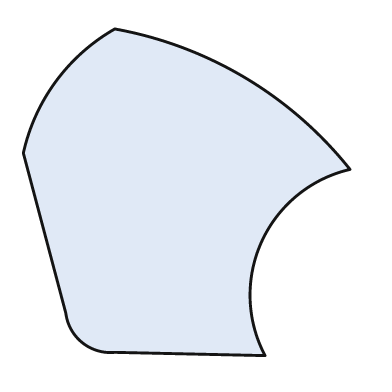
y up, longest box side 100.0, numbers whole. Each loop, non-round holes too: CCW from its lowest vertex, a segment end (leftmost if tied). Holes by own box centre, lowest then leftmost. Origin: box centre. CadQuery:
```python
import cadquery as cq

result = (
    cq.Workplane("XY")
    .moveTo(24.0, -50.0)
    .threePointArc((23.0, -15.0), (50.0, 7.0))
    .threePointArc((18.0, 35.0), (-22.0, 50.0))
    .threePointArc((-40.0, 34.0), (-50.0, 12.0))
    .lineTo(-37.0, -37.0)
    .threePointArc((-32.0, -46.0), (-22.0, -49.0))
    .close()
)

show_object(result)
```